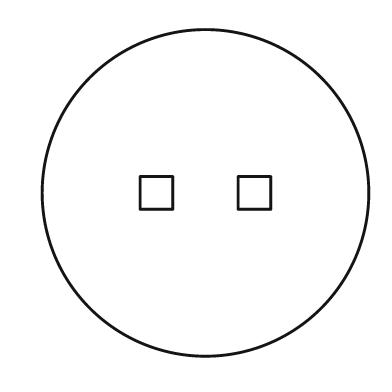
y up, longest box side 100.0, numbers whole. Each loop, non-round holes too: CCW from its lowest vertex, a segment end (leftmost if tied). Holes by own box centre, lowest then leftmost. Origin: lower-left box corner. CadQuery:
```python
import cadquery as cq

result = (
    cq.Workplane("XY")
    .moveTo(50.0, 50.0)
    .circle(50.0)
    .moveTo(30.0, 45.0)
    .lineTo(40.0, 45.0)
    .lineTo(40.0, 55.0)
    .lineTo(30.0, 55.0)
    .close()
    .moveTo(60.0, 45.0)
    .lineTo(70.0, 45.0)
    .lineTo(70.0, 55.0)
    .lineTo(60.0, 55.0)
    .close()
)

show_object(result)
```